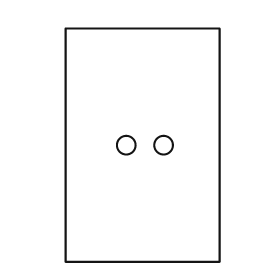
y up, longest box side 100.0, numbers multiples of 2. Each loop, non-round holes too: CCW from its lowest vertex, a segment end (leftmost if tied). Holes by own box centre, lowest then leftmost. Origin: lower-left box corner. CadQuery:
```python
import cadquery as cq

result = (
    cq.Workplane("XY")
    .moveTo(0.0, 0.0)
    .lineTo(66.0, 0.0)
    .lineTo(66.0, 100.0)
    .lineTo(0.0, 100.0)
    .close()
    .moveTo(26.0, 50.0)
    .circle(4.0)
    .moveTo(42.0, 50.0)
    .circle(4.0)
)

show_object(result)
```